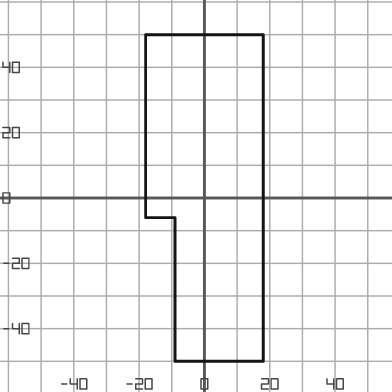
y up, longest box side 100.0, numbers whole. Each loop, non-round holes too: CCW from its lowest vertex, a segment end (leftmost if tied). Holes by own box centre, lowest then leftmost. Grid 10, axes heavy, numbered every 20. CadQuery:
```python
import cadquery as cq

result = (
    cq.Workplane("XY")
    .moveTo(-9.0, -50.0)
    .lineTo(18.0, -50.0)
    .lineTo(18.0, 50.0)
    .lineTo(-18.0, 50.0)
    .lineTo(-18.0, -6.0)
    .lineTo(-9.0, -6.0)
    .close()
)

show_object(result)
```